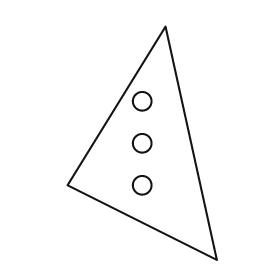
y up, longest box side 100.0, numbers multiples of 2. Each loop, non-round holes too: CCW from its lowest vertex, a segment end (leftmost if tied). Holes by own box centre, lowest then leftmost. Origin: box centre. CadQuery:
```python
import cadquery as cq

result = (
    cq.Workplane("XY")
    .moveTo(32.0, -50.0)
    .lineTo(10.0, 50.0)
    .lineTo(-32.0, -18.0)
    .close()
    .moveTo(0.0, -18.0)
    .circle(4.0)
    .moveTo(0.0, 0.0)
    .circle(4.0)
    .moveTo(0.0, 18.0)
    .circle(4.0)
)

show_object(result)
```